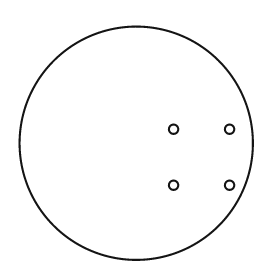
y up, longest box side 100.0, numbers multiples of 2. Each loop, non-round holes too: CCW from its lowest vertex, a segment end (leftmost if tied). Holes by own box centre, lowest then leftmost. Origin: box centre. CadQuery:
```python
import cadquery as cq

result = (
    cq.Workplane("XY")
    .moveTo(0.0, 0.0)
    .circle(50.0)
    .moveTo(16.0, -18.0)
    .circle(2.0)
    .moveTo(40.0, -18.0)
    .circle(2.0)
    .moveTo(16.0, 6.0)
    .circle(2.0)
    .moveTo(40.0, 6.0)
    .circle(2.0)
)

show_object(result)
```